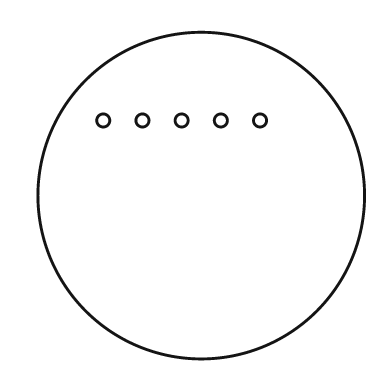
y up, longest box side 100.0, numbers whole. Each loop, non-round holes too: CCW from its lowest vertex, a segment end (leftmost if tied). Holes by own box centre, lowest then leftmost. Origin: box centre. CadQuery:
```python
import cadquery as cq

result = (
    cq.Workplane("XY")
    .moveTo(0.0, 0.0)
    .circle(50.0)
    .moveTo(-30.0, 23.0)
    .circle(2.0)
    .moveTo(-18.0, 23.0)
    .circle(2.0)
    .moveTo(-6.0, 23.0)
    .circle(2.0)
    .moveTo(6.0, 23.0)
    .circle(2.0)
    .moveTo(18.0, 23.0)
    .circle(2.0)
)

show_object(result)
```